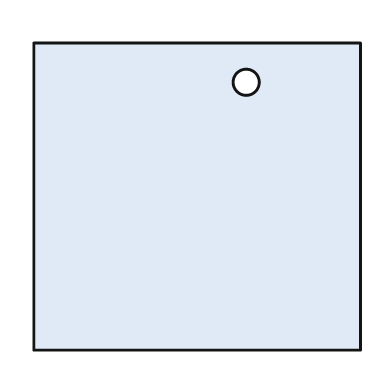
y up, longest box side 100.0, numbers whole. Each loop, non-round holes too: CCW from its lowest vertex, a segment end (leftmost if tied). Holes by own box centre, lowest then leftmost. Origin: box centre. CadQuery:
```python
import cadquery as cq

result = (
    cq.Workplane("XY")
    .moveTo(-50.0, -47.0)
    .lineTo(50.0, -47.0)
    .lineTo(50.0, 47.0)
    .lineTo(-50.0, 47.0)
    .close()
    .moveTo(15.0, 35.0)
    .circle(4.0)
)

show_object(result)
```